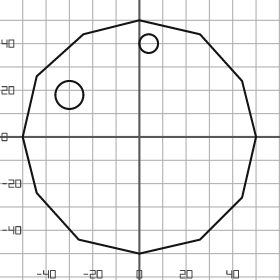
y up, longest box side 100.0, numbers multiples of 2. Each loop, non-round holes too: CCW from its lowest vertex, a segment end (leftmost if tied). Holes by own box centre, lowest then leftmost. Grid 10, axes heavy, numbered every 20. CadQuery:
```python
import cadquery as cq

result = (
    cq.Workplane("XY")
    .moveTo(0.0, -50.0)
    .lineTo(26.0, -44.0)
    .lineTo(44.0, -26.0)
    .lineTo(50.0, 0.0)
    .lineTo(44.0, 24.0)
    .lineTo(26.0, 44.0)
    .lineTo(0.0, 50.0)
    .lineTo(-24.0, 44.0)
    .lineTo(-44.0, 26.0)
    .lineTo(-50.0, 0.0)
    .lineTo(-44.0, -24.0)
    .lineTo(-26.0, -44.0)
    .close()
    .moveTo(-30.0, 18.0)
    .circle(6.0)
    .moveTo(4.0, 40.0)
    .circle(4.0)
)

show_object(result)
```